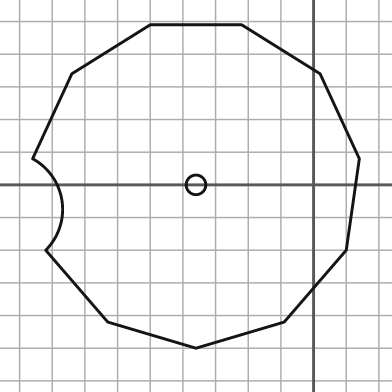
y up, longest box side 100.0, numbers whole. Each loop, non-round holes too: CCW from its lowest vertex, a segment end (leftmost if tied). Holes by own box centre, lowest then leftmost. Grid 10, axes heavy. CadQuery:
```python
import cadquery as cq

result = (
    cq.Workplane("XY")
    .moveTo(-36.0, -50.0)
    .lineTo(-9.0, -42.0)
    .lineTo(10.0, -20.0)
    .lineTo(14.0, 8.0)
    .lineTo(2.0, 34.0)
    .lineTo(-22.0, 49.0)
    .lineTo(-50.0, 49.0)
    .lineTo(-74.0, 34.0)
    .lineTo(-86.0, 8.0)
    .threePointArc((-77.0, -5.0), (-82.0, -20.0))
    .lineTo(-63.0, -42.0)
    .close()
    .moveTo(-36.0, 0.0)
    .circle(3.0)
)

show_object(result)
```